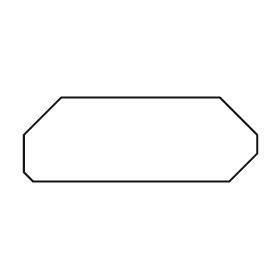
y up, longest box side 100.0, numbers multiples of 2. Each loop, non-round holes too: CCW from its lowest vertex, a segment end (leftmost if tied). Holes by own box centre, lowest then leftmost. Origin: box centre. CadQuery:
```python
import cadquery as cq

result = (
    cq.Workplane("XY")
    .moveTo(-46.0, -18.0)
    .lineTo(38.0, -18.0)
    .lineTo(50.0, -6.0)
    .lineTo(50.0, 2.0)
    .lineTo(34.0, 18.0)
    .lineTo(-34.0, 18.0)
    .lineTo(-50.0, 2.0)
    .lineTo(-50.0, -14.0)
    .close()
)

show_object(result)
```